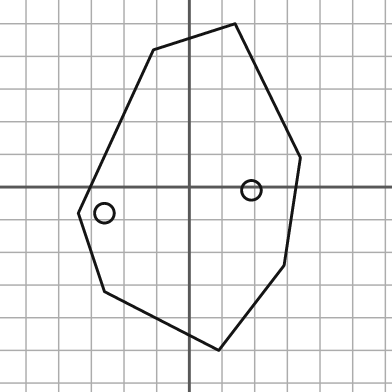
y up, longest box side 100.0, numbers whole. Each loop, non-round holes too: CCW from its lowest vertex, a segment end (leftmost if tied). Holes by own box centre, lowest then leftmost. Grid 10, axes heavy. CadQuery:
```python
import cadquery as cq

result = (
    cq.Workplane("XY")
    .moveTo(9.0, -50.0)
    .lineTo(29.0, -24.0)
    .lineTo(34.0, 9.0)
    .lineTo(14.0, 50.0)
    .lineTo(-11.0, 42.0)
    .lineTo(-34.0, -8.0)
    .lineTo(-26.0, -32.0)
    .close()
    .moveTo(-26.0, -8.0)
    .circle(3.0)
    .moveTo(19.0, -1.0)
    .circle(3.0)
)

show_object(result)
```